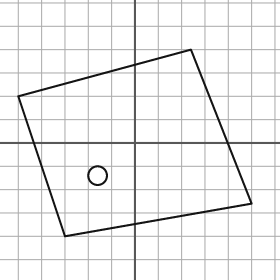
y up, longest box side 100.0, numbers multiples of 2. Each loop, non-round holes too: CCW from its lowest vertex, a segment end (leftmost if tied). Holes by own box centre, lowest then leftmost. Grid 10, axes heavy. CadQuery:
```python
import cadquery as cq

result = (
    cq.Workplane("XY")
    .moveTo(-30.0, -40.0)
    .lineTo(50.0, -26.0)
    .lineTo(24.0, 40.0)
    .lineTo(-50.0, 20.0)
    .close()
    .moveTo(-16.0, -14.0)
    .circle(4.0)
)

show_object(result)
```